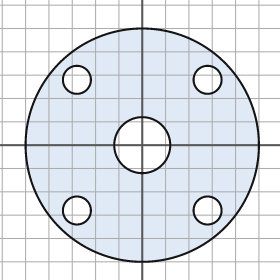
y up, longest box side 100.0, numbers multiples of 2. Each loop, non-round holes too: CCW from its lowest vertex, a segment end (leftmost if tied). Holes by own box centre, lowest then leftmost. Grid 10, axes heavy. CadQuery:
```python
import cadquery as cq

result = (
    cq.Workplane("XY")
    .moveTo(0.0, 0.0)
    .circle(50.0)
    .moveTo(-28.0, -28.0)
    .circle(6.0)
    .moveTo(28.0, -28.0)
    .circle(6.0)
    .moveTo(0.0, 0.0)
    .circle(12.0)
    .moveTo(-28.0, 28.0)
    .circle(6.0)
    .moveTo(28.0, 28.0)
    .circle(6.0)
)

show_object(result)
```